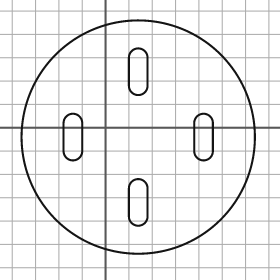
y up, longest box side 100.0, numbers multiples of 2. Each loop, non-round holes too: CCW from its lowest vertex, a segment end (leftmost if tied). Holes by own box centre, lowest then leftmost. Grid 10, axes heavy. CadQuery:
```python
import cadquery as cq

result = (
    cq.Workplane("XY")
    .moveTo(14.0, -4.0)
    .circle(50.0)
    .moveTo(10.0, -38.0)
    .threePointArc((14.0, -42.0), (18.0, -38.0))
    .lineTo(18.0, -26.0)
    .threePointArc((14.0, -22.0), (10.0, -26.0))
    .close()
    .moveTo(-18.0, -10.0)
    .threePointArc((-14.0, -14.0), (-10.0, -10.0))
    .lineTo(-10.0, 2.0)
    .threePointArc((-14.0, 6.0), (-18.0, 2.0))
    .close()
    .moveTo(38.0, -10.0)
    .threePointArc((42.0, -14.0), (46.0, -10.0))
    .lineTo(46.0, 2.0)
    .threePointArc((42.0, 6.0), (38.0, 2.0))
    .close()
    .moveTo(10.0, 18.0)
    .threePointArc((14.0, 14.0), (18.0, 18.0))
    .lineTo(18.0, 30.0)
    .threePointArc((14.0, 34.0), (10.0, 30.0))
    .close()
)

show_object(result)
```